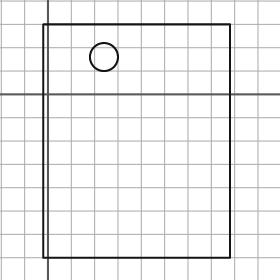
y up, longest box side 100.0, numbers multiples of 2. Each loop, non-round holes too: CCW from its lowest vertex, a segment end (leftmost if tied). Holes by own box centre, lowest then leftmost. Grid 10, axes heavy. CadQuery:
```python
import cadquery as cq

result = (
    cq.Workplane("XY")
    .moveTo(-2.0, -70.0)
    .lineTo(78.0, -70.0)
    .lineTo(78.0, 30.0)
    .lineTo(-2.0, 30.0)
    .close()
    .moveTo(24.0, 16.0)
    .circle(6.0)
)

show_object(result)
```